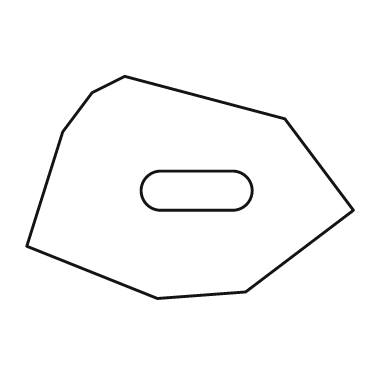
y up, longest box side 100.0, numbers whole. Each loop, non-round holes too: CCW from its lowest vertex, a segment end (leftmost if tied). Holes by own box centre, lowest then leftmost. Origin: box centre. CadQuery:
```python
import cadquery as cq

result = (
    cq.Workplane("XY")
    .moveTo(-10.0, -34.0)
    .lineTo(17.0, -32.0)
    .lineTo(50.0, -7.0)
    .lineTo(29.0, 21.0)
    .lineTo(-20.0, 34.0)
    .lineTo(-30.0, 29.0)
    .lineTo(-39.0, 17.0)
    .lineTo(-50.0, -18.0)
    .close()
    .moveTo(-9.0, -7.0)
    .lineTo(13.0, -7.0)
    .threePointArc((19.0, -1.0), (13.0, 5.0))
    .lineTo(-9.0, 5.0)
    .threePointArc((-15.0, -1.0), (-9.0, -7.0))
    .close()
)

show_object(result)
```